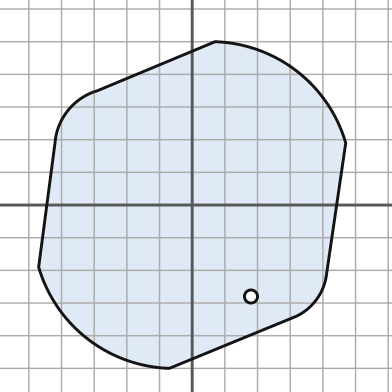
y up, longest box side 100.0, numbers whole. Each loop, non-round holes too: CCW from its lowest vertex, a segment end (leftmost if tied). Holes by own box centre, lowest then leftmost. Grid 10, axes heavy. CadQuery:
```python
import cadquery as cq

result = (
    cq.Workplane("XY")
    .moveTo(-7.0, -50.0)
    .lineTo(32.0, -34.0)
    .threePointArc((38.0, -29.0), (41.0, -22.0))
    .lineTo(47.0, 19.0)
    .threePointArc((32.0, 41.0), (7.0, 50.0))
    .lineTo(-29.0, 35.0)
    .threePointArc((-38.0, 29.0), (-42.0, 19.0))
    .lineTo(-47.0, -19.0)
    .threePointArc((-32.0, -41.0), (-7.0, -50.0))
    .close()
    .moveTo(18.0, -28.0)
    .circle(2.0)
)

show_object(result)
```